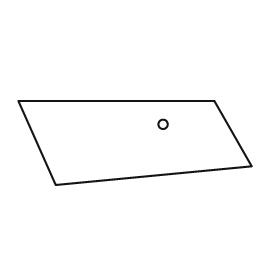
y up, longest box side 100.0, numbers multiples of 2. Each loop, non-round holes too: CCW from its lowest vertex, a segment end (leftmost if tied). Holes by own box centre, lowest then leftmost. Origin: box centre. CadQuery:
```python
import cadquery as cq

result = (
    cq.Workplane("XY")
    .moveTo(-34.0, -18.0)
    .lineTo(50.0, -10.0)
    .lineTo(34.0, 18.0)
    .lineTo(-50.0, 18.0)
    .close()
    .moveTo(12.0, 8.0)
    .circle(2.0)
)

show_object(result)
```